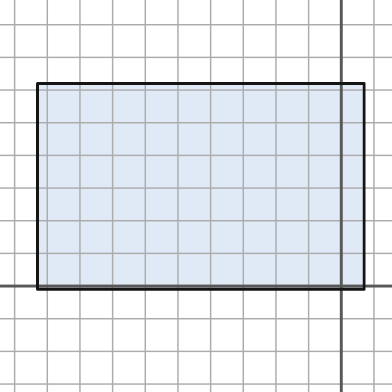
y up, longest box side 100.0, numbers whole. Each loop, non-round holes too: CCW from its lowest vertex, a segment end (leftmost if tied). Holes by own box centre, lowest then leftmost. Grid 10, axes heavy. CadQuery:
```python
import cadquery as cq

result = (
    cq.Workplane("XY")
    .moveTo(-93.0, -1.0)
    .lineTo(7.0, -1.0)
    .lineTo(7.0, 62.0)
    .lineTo(-93.0, 62.0)
    .close()
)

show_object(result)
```